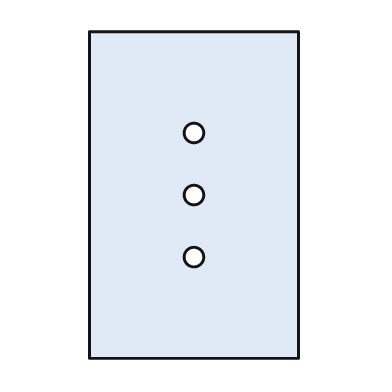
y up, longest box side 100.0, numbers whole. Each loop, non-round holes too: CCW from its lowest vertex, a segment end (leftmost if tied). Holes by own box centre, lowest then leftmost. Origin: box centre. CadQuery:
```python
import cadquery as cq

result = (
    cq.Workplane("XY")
    .moveTo(-32.0, -50.0)
    .lineTo(32.0, -50.0)
    .lineTo(32.0, 50.0)
    .lineTo(-32.0, 50.0)
    .close()
    .moveTo(0.0, -19.0)
    .circle(3.0)
    .moveTo(0.0, 0.0)
    .circle(3.0)
    .moveTo(0.0, 19.0)
    .circle(3.0)
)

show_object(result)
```